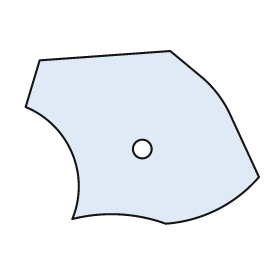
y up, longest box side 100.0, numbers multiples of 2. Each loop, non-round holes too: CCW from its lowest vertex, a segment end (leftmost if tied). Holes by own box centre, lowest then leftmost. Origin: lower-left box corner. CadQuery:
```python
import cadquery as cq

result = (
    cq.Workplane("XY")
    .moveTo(60.0, 0.0)
    .threePointArc((82.0, 6.0), (100.0, 20.0))
    .lineTo(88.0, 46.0)
    .threePointArc((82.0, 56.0), (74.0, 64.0))
    .lineTo(62.0, 74.0)
    .lineTo(6.0, 70.0)
    .lineTo(0.0, 50.0)
    .threePointArc((20.0, 30.0), (20.0, 2.0))
    .threePointArc((40.0, 4.0), (60.0, 0.0))
    .close()
    .moveTo(50.0, 32.0)
    .circle(4.0)
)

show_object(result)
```